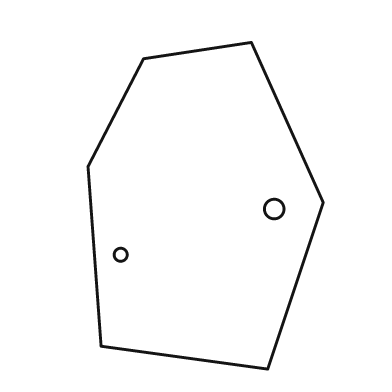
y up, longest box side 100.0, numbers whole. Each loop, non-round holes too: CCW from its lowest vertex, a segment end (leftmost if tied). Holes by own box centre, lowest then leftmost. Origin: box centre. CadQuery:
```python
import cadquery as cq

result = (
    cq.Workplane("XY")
    .moveTo(19.0, -50.0)
    .lineTo(36.0, 1.0)
    .lineTo(14.0, 50.0)
    .lineTo(-19.0, 45.0)
    .lineTo(-36.0, 12.0)
    .lineTo(-32.0, -43.0)
    .close()
    .moveTo(-26.0, -15.0)
    .circle(2.0)
    .moveTo(21.0, -1.0)
    .circle(3.0)
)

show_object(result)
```